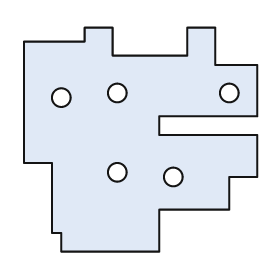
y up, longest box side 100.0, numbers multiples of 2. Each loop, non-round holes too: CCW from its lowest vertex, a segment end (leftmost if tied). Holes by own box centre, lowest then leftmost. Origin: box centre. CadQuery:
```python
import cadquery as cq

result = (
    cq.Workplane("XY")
    .moveTo(-34.0, -48.0)
    .lineTo(8.0, -48.0)
    .lineTo(8.0, -30.0)
    .lineTo(38.0, -30.0)
    .lineTo(38.0, -16.0)
    .lineTo(50.0, -16.0)
    .lineTo(50.0, 2.0)
    .lineTo(8.0, 2.0)
    .lineTo(8.0, 10.0)
    .lineTo(50.0, 10.0)
    .lineTo(50.0, 32.0)
    .lineTo(32.0, 32.0)
    .lineTo(32.0, 48.0)
    .lineTo(20.0, 48.0)
    .lineTo(20.0, 36.0)
    .lineTo(-12.0, 36.0)
    .lineTo(-12.0, 48.0)
    .lineTo(-24.0, 48.0)
    .lineTo(-24.0, 42.0)
    .lineTo(-50.0, 42.0)
    .lineTo(-50.0, -10.0)
    .lineTo(-38.0, -10.0)
    .lineTo(-38.0, -40.0)
    .lineTo(-34.0, -40.0)
    .close()
    .moveTo(14.0, -16.0)
    .circle(4.0)
    .moveTo(-10.0, -14.0)
    .circle(4.0)
    .moveTo(-34.0, 18.0)
    .circle(4.0)
    .moveTo(-10.0, 20.0)
    .circle(4.0)
    .moveTo(38.0, 20.0)
    .circle(4.0)
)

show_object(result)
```